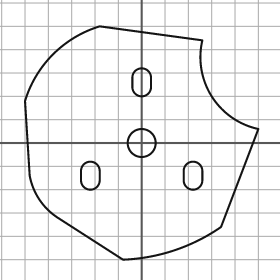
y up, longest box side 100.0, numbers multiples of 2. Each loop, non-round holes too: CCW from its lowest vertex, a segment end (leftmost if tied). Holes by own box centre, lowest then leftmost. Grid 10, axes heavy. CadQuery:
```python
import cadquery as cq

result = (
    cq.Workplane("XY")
    .moveTo(-8.0, -50.0)
    .threePointArc((14.0, -46.0), (34.0, -36.0))
    .lineTo(50.0, 6.0)
    .threePointArc((30.0, 20.0), (26.0, 44.0))
    .lineTo(-18.0, 50.0)
    .threePointArc((-38.0, 38.0), (-50.0, 18.0))
    .lineTo(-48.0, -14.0)
    .threePointArc((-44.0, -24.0), (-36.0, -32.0))
    .close()
    .moveTo(-26.0, -16.0)
    .threePointArc((-22.0, -20.0), (-18.0, -16.0))
    .lineTo(-18.0, -12.0)
    .threePointArc((-22.0, -8.0), (-26.0, -12.0))
    .close()
    .moveTo(18.0, -16.0)
    .threePointArc((22.0, -20.0), (26.0, -16.0))
    .lineTo(26.0, -12.0)
    .threePointArc((22.0, -8.0), (18.0, -12.0))
    .close()
    .moveTo(0.0, 0.0)
    .circle(6.0)
    .moveTo(-4.0, 24.0)
    .threePointArc((0.0, 20.0), (4.0, 24.0))
    .lineTo(4.0, 28.0)
    .threePointArc((0.0, 32.0), (-4.0, 28.0))
    .close()
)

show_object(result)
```